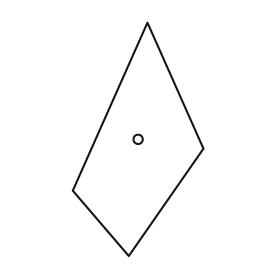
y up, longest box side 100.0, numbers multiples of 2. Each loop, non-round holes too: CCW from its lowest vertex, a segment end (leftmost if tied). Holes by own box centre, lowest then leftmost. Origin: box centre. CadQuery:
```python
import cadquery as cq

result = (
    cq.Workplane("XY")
    .moveTo(-4.0, -50.0)
    .lineTo(28.0, -4.0)
    .lineTo(4.0, 50.0)
    .lineTo(-28.0, -22.0)
    .close()
    .moveTo(0.0, 0.0)
    .circle(2.0)
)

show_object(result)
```